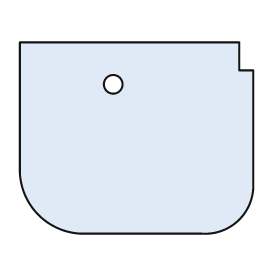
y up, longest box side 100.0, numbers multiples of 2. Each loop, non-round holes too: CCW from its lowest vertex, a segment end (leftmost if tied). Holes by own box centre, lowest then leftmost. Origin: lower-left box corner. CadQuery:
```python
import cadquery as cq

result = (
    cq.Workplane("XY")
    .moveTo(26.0, 0.0)
    .lineTo(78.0, 0.0)
    .threePointArc((94.0, 6.0), (100.0, 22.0))
    .lineTo(100.0, 70.0)
    .lineTo(94.0, 70.0)
    .lineTo(94.0, 82.0)
    .lineTo(0.0, 82.0)
    .lineTo(0.0, 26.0)
    .threePointArc((8.0, 8.0), (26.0, 0.0))
    .close()
    .moveTo(40.0, 64.0)
    .circle(4.0)
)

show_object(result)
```